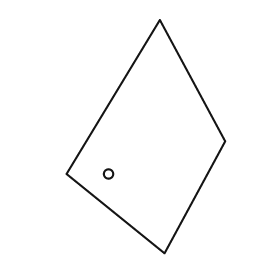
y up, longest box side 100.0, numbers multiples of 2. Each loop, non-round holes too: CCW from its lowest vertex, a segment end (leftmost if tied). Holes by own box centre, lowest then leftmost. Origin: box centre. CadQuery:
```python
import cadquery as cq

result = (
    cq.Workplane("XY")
    .moveTo(8.0, -50.0)
    .lineTo(34.0, -2.0)
    .lineTo(6.0, 50.0)
    .lineTo(-34.0, -16.0)
    .close()
    .moveTo(-16.0, -16.0)
    .circle(2.0)
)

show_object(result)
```